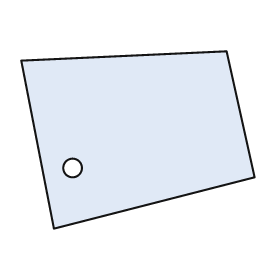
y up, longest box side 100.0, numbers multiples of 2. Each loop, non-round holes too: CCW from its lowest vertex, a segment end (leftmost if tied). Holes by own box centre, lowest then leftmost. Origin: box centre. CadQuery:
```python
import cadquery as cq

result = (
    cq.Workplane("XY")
    .moveTo(-36.0, -38.0)
    .lineTo(50.0, -16.0)
    .lineTo(38.0, 38.0)
    .lineTo(-50.0, 34.0)
    .close()
    .moveTo(-28.0, -12.0)
    .circle(4.0)
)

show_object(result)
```